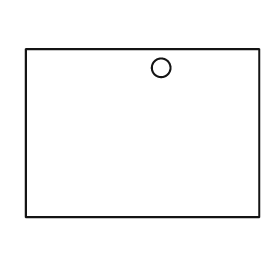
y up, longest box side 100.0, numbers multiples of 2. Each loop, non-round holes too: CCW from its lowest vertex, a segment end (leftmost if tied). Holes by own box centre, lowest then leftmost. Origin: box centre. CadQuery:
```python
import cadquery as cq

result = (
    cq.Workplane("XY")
    .moveTo(-50.0, -36.0)
    .lineTo(50.0, -36.0)
    .lineTo(50.0, 36.0)
    .lineTo(-50.0, 36.0)
    .close()
    .moveTo(8.0, 28.0)
    .circle(4.0)
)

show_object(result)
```